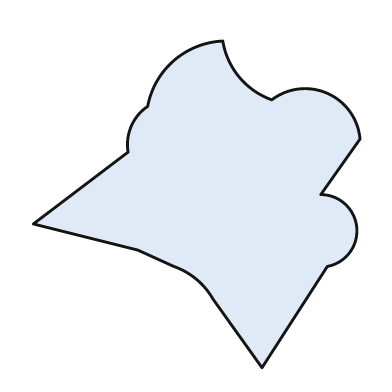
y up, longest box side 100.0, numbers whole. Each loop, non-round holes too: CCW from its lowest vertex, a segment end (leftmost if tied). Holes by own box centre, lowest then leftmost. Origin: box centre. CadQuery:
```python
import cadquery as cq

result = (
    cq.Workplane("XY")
    .moveTo(20.0, -50.0)
    .lineTo(40.0, -19.0)
    .threePointArc((49.0, -7.0), (38.0, 3.0))
    .lineTo(50.0, 20.0)
    .threePointArc((40.0, 34.0), (23.0, 32.0))
    .threePointArc((13.0, 39.0), (8.0, 50.0))
    .threePointArc((-7.0, 44.0), (-15.0, 30.0))
    .threePointArc((-20.0, 24.0), (-21.0, 16.0))
    .lineTo(-50.0, -6.0)
    .lineTo(-18.0, -14.0)
    .lineTo(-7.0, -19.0)
    .threePointArc((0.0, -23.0), (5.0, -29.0))
    .close()
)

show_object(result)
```